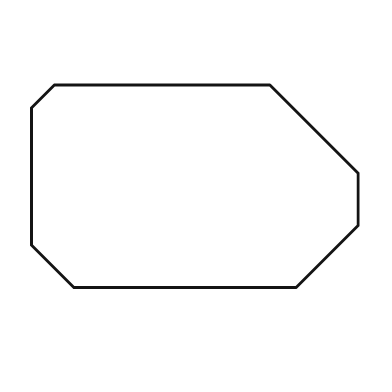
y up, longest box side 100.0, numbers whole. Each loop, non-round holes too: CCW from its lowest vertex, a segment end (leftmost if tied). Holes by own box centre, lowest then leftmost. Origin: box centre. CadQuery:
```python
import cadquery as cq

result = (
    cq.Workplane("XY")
    .moveTo(-37.0, -31.0)
    .lineTo(31.0, -31.0)
    .lineTo(50.0, -12.0)
    .lineTo(50.0, 4.0)
    .lineTo(23.0, 31.0)
    .lineTo(-43.0, 31.0)
    .lineTo(-50.0, 24.0)
    .lineTo(-50.0, -18.0)
    .close()
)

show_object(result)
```